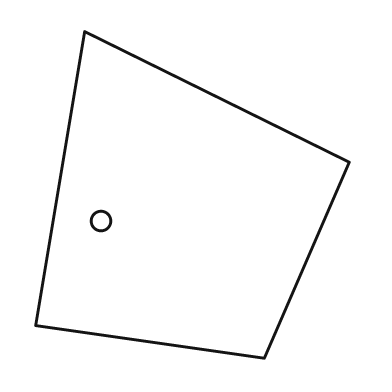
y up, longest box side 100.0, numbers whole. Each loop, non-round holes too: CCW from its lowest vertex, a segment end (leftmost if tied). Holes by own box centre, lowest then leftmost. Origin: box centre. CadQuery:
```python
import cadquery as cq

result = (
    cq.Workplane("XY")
    .moveTo(22.0, -50.0)
    .lineTo(48.0, 10.0)
    .lineTo(-33.0, 50.0)
    .lineTo(-48.0, -40.0)
    .close()
    .moveTo(-28.0, -8.0)
    .circle(3.0)
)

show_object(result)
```